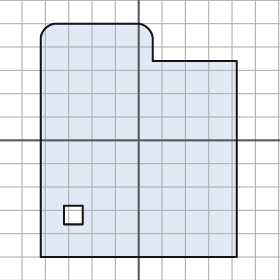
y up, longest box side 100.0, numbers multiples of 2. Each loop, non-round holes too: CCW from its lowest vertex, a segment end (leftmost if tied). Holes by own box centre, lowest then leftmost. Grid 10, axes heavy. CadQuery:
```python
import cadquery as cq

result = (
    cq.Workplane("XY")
    .moveTo(-42.0, -50.0)
    .lineTo(42.0, -50.0)
    .lineTo(42.0, 34.0)
    .lineTo(6.0, 34.0)
    .lineTo(6.0, 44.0)
    .threePointArc((4.0, 48.0), (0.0, 50.0))
    .lineTo(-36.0, 50.0)
    .threePointArc((-40.0, 48.0), (-42.0, 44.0))
    .close()
    .moveTo(-32.0, -36.0)
    .lineTo(-24.0, -36.0)
    .lineTo(-24.0, -28.0)
    .lineTo(-32.0, -28.0)
    .close()
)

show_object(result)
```